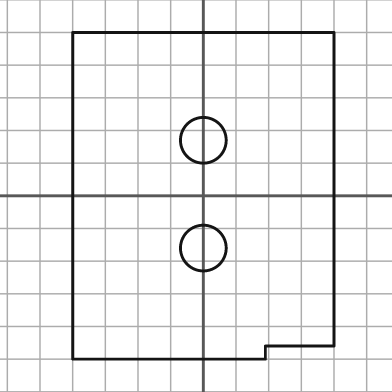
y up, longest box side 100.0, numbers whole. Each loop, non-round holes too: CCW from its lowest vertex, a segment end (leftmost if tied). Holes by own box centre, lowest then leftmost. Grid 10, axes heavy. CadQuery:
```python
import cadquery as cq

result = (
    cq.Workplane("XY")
    .moveTo(-40.0, -50.0)
    .lineTo(19.0, -50.0)
    .lineTo(19.0, -46.0)
    .lineTo(40.0, -46.0)
    .lineTo(40.0, 50.0)
    .lineTo(-40.0, 50.0)
    .close()
    .moveTo(0.0, -16.0)
    .circle(7.0)
    .moveTo(0.0, 17.0)
    .circle(7.0)
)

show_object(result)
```